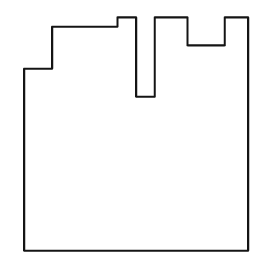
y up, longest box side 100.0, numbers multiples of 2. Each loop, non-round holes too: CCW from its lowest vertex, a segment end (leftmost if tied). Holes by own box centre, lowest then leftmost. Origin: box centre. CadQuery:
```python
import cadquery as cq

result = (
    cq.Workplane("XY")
    .moveTo(-48.0, -50.0)
    .lineTo(48.0, -50.0)
    .lineTo(48.0, 50.0)
    .lineTo(38.0, 50.0)
    .lineTo(38.0, 38.0)
    .lineTo(22.0, 38.0)
    .lineTo(22.0, 50.0)
    .lineTo(8.0, 50.0)
    .lineTo(8.0, 16.0)
    .lineTo(0.0, 16.0)
    .lineTo(0.0, 50.0)
    .lineTo(-8.0, 50.0)
    .lineTo(-8.0, 46.0)
    .lineTo(-36.0, 46.0)
    .lineTo(-36.0, 28.0)
    .lineTo(-48.0, 28.0)
    .close()
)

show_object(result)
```